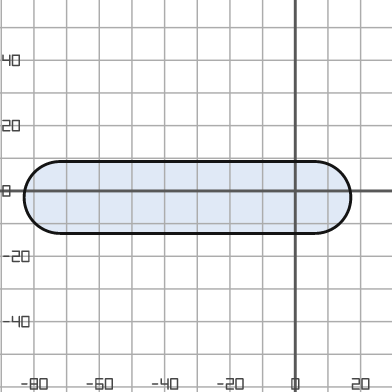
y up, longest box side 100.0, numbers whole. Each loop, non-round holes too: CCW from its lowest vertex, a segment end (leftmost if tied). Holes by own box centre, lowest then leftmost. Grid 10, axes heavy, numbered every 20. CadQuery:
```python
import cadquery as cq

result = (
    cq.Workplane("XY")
    .moveTo(-72.0, -13.0)
    .lineTo(6.0, -13.0)
    .threePointArc((17.0, -2.0), (6.0, 9.0))
    .lineTo(-72.0, 9.0)
    .threePointArc((-83.0, -2.0), (-72.0, -13.0))
    .close()
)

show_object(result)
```